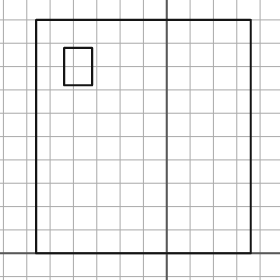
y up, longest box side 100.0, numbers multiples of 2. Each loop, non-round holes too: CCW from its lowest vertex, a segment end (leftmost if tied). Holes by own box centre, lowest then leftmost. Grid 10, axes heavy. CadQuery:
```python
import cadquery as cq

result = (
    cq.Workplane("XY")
    .moveTo(-56.0, 0.0)
    .lineTo(36.0, 0.0)
    .lineTo(36.0, 100.0)
    .lineTo(-56.0, 100.0)
    .close()
    .moveTo(-44.0, 72.0)
    .lineTo(-32.0, 72.0)
    .lineTo(-32.0, 88.0)
    .lineTo(-44.0, 88.0)
    .close()
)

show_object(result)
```